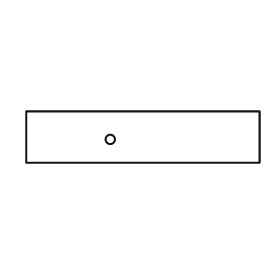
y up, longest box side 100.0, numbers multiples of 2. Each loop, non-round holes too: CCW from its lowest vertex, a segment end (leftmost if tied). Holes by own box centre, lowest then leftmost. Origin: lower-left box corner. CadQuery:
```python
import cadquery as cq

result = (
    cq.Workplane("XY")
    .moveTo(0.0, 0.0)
    .lineTo(100.0, 0.0)
    .lineTo(100.0, 22.0)
    .lineTo(0.0, 22.0)
    .close()
    .moveTo(36.0, 10.0)
    .circle(2.0)
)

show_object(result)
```